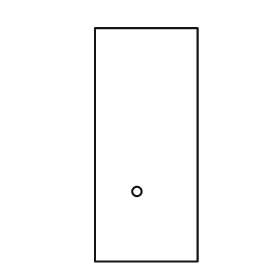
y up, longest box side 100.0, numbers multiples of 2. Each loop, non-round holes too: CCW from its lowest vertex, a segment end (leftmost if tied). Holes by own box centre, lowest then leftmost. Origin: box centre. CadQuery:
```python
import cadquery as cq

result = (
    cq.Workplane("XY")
    .moveTo(-22.0, -50.0)
    .lineTo(22.0, -50.0)
    .lineTo(22.0, 50.0)
    .lineTo(-22.0, 50.0)
    .close()
    .moveTo(-4.0, -20.0)
    .circle(2.0)
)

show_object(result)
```